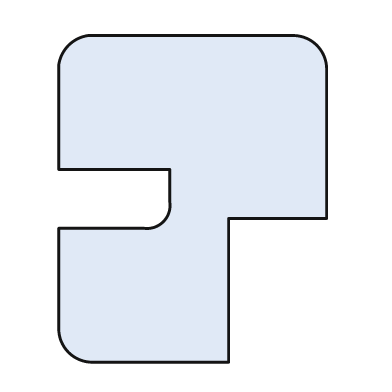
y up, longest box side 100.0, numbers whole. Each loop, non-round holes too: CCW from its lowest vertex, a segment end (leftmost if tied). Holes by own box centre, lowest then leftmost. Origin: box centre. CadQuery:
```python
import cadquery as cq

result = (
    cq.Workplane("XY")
    .moveTo(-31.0, -50.0)
    .lineTo(11.0, -50.0)
    .lineTo(11.0, -6.0)
    .lineTo(41.0, -6.0)
    .lineTo(41.0, 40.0)
    .threePointArc((38.0, 47.0), (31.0, 50.0))
    .lineTo(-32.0, 50.0)
    .threePointArc((-38.0, 47.0), (-41.0, 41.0))
    .lineTo(-41.0, 9.0)
    .lineTo(-7.0, 9.0)
    .lineTo(-7.0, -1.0)
    .threePointArc((-9.0, -7.0), (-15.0, -9.0))
    .lineTo(-41.0, -9.0)
    .lineTo(-41.0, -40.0)
    .threePointArc((-38.0, -47.0), (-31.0, -50.0))
    .close()
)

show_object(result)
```